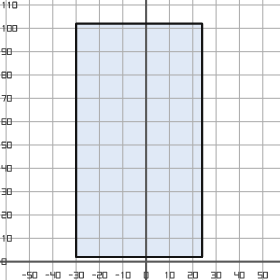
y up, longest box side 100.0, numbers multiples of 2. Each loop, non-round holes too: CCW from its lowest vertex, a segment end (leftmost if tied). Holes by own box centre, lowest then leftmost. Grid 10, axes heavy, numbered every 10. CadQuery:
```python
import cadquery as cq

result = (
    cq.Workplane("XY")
    .moveTo(-30.0, 2.0)
    .lineTo(24.0, 2.0)
    .lineTo(24.0, 102.0)
    .lineTo(-30.0, 102.0)
    .close()
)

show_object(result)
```